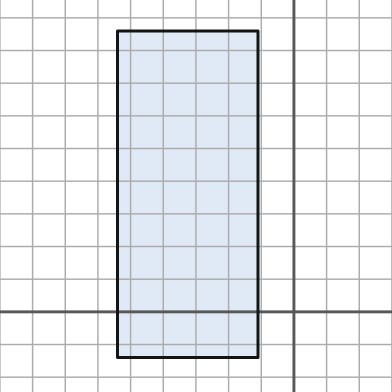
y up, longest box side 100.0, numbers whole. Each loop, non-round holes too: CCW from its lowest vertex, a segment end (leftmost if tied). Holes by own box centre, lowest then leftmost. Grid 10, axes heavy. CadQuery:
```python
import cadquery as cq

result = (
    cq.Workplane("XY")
    .moveTo(-54.0, -14.0)
    .lineTo(-11.0, -14.0)
    .lineTo(-11.0, 86.0)
    .lineTo(-54.0, 86.0)
    .close()
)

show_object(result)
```